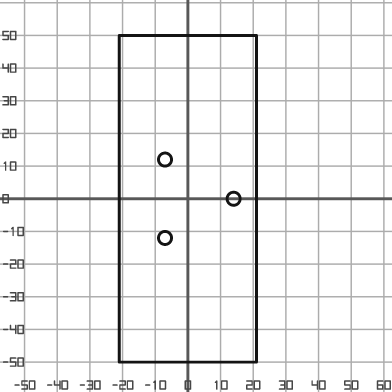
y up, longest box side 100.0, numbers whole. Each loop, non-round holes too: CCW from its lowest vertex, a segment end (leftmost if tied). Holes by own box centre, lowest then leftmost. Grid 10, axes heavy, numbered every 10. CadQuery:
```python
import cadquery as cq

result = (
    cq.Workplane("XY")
    .moveTo(-21.0, -50.0)
    .lineTo(21.0, -50.0)
    .lineTo(21.0, 50.0)
    .lineTo(-21.0, 50.0)
    .close()
    .moveTo(-7.0, -12.0)
    .circle(2.0)
    .moveTo(14.0, 0.0)
    .circle(2.0)
    .moveTo(-7.0, 12.0)
    .circle(2.0)
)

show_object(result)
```